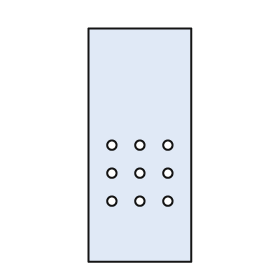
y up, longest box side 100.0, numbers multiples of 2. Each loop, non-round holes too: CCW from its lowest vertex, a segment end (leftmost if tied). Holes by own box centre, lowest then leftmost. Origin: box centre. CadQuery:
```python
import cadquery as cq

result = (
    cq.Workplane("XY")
    .moveTo(-22.0, -50.0)
    .lineTo(22.0, -50.0)
    .lineTo(22.0, 50.0)
    .lineTo(-22.0, 50.0)
    .close()
    .moveTo(-12.0, -24.0)
    .circle(2.0)
    .moveTo(0.0, -24.0)
    .circle(2.0)
    .moveTo(12.0, -24.0)
    .circle(2.0)
    .moveTo(-12.0, -12.0)
    .circle(2.0)
    .moveTo(0.0, -12.0)
    .circle(2.0)
    .moveTo(12.0, -12.0)
    .circle(2.0)
    .moveTo(-12.0, 0.0)
    .circle(2.0)
    .moveTo(0.0, 0.0)
    .circle(2.0)
    .moveTo(12.0, 0.0)
    .circle(2.0)
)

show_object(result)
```